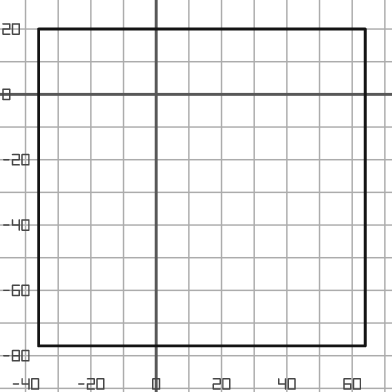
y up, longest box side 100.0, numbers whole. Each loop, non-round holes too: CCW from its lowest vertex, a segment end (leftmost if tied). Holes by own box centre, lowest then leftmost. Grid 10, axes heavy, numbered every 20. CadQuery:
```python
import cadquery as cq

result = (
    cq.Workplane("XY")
    .moveTo(-36.0, -77.0)
    .lineTo(64.0, -77.0)
    .lineTo(64.0, 20.0)
    .lineTo(-36.0, 20.0)
    .close()
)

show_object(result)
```